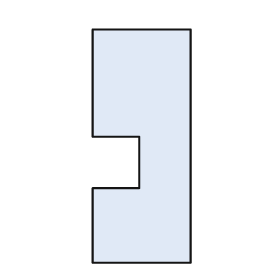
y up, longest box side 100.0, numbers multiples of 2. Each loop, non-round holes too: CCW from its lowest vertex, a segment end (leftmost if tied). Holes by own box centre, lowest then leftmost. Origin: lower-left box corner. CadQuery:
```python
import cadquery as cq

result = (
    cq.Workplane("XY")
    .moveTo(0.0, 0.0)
    .lineTo(42.0, 0.0)
    .lineTo(42.0, 100.0)
    .lineTo(0.0, 100.0)
    .lineTo(0.0, 54.0)
    .lineTo(20.0, 54.0)
    .lineTo(20.0, 32.0)
    .lineTo(0.0, 32.0)
    .close()
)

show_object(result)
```